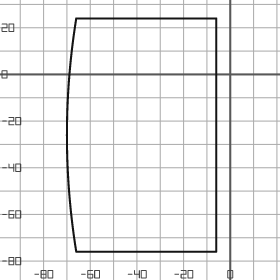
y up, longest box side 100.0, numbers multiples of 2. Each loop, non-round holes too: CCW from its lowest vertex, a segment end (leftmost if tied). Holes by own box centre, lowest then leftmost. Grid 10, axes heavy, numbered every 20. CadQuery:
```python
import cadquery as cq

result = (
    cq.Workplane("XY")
    .moveTo(-66.0, -76.0)
    .lineTo(-6.0, -76.0)
    .lineTo(-6.0, 24.0)
    .lineTo(-66.0, 24.0)
    .threePointArc((-70.0, -26.0), (-66.0, -76.0))
    .close()
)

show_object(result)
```